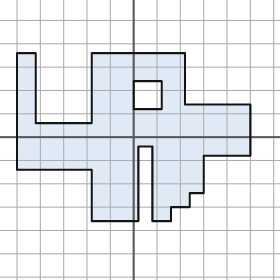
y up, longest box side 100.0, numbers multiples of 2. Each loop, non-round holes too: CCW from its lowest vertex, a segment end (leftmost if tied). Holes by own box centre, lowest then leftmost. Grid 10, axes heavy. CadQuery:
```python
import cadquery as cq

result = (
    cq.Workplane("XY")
    .moveTo(-18.0, -36.0)
    .lineTo(2.0, -36.0)
    .lineTo(2.0, -4.0)
    .lineTo(8.0, -4.0)
    .lineTo(8.0, -36.0)
    .lineTo(16.0, -36.0)
    .lineTo(16.0, -30.0)
    .lineTo(24.0, -30.0)
    .lineTo(24.0, -24.0)
    .lineTo(30.0, -24.0)
    .lineTo(30.0, -8.0)
    .lineTo(50.0, -8.0)
    .lineTo(50.0, 14.0)
    .lineTo(22.0, 14.0)
    .lineTo(22.0, 36.0)
    .lineTo(-18.0, 36.0)
    .lineTo(-18.0, 6.0)
    .lineTo(-42.0, 6.0)
    .lineTo(-42.0, 36.0)
    .lineTo(-50.0, 36.0)
    .lineTo(-50.0, -14.0)
    .lineTo(-18.0, -14.0)
    .close()
    .moveTo(0.0, 12.0)
    .lineTo(12.0, 12.0)
    .lineTo(12.0, 24.0)
    .lineTo(0.0, 24.0)
    .close()
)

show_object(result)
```